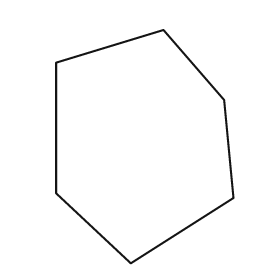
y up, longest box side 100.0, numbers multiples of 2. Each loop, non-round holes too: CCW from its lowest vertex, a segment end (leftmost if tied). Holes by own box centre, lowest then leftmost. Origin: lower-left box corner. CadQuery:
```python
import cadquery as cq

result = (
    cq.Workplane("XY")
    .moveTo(32.0, 0.0)
    .lineTo(76.0, 28.0)
    .lineTo(72.0, 70.0)
    .lineTo(46.0, 100.0)
    .lineTo(0.0, 86.0)
    .lineTo(0.0, 30.0)
    .close()
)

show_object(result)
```